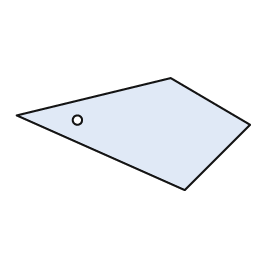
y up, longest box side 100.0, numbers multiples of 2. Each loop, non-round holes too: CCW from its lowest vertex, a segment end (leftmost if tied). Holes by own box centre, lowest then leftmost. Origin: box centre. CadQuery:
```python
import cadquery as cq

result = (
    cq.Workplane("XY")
    .moveTo(22.0, -24.0)
    .lineTo(50.0, 4.0)
    .lineTo(16.0, 24.0)
    .lineTo(-50.0, 8.0)
    .close()
    .moveTo(-24.0, 6.0)
    .circle(2.0)
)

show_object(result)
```